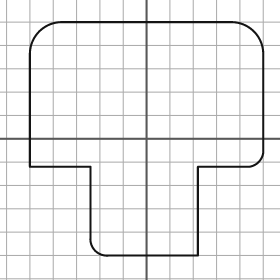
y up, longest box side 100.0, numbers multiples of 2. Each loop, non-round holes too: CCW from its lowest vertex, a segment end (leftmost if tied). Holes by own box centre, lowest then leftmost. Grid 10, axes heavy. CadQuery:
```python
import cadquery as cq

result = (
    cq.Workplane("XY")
    .moveTo(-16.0, -50.0)
    .lineTo(22.0, -50.0)
    .lineTo(22.0, -12.0)
    .lineTo(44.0, -12.0)
    .threePointArc((48.0, -10.0), (50.0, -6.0))
    .lineTo(50.0, 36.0)
    .threePointArc((46.0, 46.0), (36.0, 50.0))
    .lineTo(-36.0, 50.0)
    .threePointArc((-46.0, 46.0), (-50.0, 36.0))
    .lineTo(-50.0, -12.0)
    .lineTo(-24.0, -12.0)
    .lineTo(-24.0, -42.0)
    .threePointArc((-22.0, -48.0), (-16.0, -50.0))
    .close()
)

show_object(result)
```